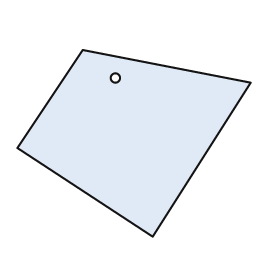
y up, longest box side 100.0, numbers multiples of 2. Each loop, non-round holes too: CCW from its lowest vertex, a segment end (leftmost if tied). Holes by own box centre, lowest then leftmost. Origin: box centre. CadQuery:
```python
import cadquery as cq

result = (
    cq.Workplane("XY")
    .moveTo(8.0, -40.0)
    .lineTo(50.0, 26.0)
    .lineTo(-22.0, 40.0)
    .lineTo(-50.0, -2.0)
    .close()
    .moveTo(-8.0, 28.0)
    .circle(2.0)
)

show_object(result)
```